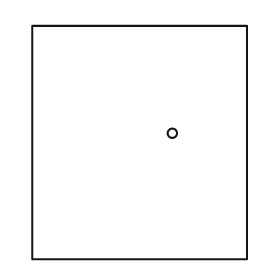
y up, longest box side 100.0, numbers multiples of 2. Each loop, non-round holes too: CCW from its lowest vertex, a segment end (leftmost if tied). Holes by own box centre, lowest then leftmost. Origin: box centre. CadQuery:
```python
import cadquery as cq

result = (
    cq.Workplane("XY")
    .moveTo(-46.0, -50.0)
    .lineTo(46.0, -50.0)
    .lineTo(46.0, 50.0)
    .lineTo(-46.0, 50.0)
    .close()
    .moveTo(14.0, 4.0)
    .circle(2.0)
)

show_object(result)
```